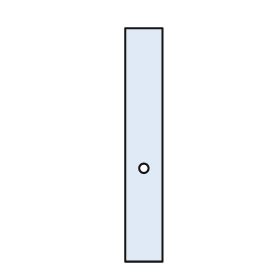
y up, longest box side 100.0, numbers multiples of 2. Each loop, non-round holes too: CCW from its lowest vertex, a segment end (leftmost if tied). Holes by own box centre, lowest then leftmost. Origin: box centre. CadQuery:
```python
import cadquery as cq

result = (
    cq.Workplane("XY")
    .moveTo(-8.0, -50.0)
    .lineTo(8.0, -50.0)
    .lineTo(8.0, 50.0)
    .lineTo(-8.0, 50.0)
    .close()
    .moveTo(0.0, -10.0)
    .circle(2.0)
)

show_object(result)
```